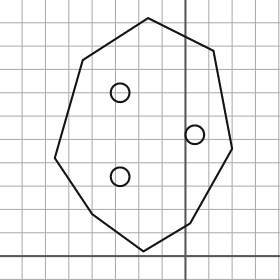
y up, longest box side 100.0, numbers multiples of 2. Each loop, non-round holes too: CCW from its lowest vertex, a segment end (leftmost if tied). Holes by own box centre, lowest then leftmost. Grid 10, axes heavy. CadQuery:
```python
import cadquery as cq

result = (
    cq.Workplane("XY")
    .moveTo(-18.0, 2.0)
    .lineTo(2.0, 14.0)
    .lineTo(20.0, 46.0)
    .lineTo(12.0, 88.0)
    .lineTo(-16.0, 102.0)
    .lineTo(-44.0, 84.0)
    .lineTo(-56.0, 42.0)
    .lineTo(-40.0, 18.0)
    .close()
    .moveTo(-28.0, 34.0)
    .circle(4.0)
    .moveTo(4.0, 52.0)
    .circle(4.0)
    .moveTo(-28.0, 70.0)
    .circle(4.0)
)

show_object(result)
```